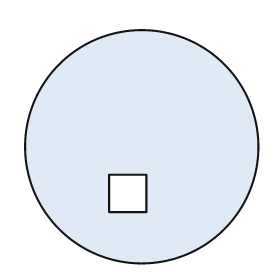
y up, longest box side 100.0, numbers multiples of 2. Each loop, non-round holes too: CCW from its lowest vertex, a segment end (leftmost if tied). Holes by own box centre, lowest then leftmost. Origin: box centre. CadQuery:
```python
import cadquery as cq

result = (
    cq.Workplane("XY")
    .moveTo(0.0, 0.0)
    .circle(50.0)
    .moveTo(-14.0, -28.0)
    .lineTo(2.0, -28.0)
    .lineTo(2.0, -12.0)
    .lineTo(-14.0, -12.0)
    .close()
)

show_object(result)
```